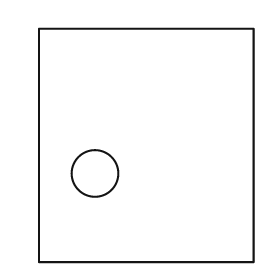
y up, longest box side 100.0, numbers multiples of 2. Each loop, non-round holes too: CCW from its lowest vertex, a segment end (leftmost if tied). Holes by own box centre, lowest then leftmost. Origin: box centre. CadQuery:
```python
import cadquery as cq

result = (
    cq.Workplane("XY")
    .moveTo(-46.0, -50.0)
    .lineTo(46.0, -50.0)
    .lineTo(46.0, 50.0)
    .lineTo(-46.0, 50.0)
    .close()
    .moveTo(-22.0, -12.0)
    .circle(10.0)
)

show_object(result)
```